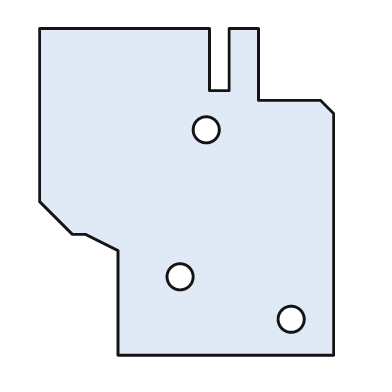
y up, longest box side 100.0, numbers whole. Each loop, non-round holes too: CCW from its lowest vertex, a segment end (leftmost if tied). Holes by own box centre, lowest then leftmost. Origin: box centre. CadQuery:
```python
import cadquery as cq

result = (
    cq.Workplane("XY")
    .moveTo(-21.0, -50.0)
    .lineTo(45.0, -50.0)
    .lineTo(45.0, 24.0)
    .lineTo(41.0, 28.0)
    .lineTo(22.0, 28.0)
    .lineTo(22.0, 50.0)
    .lineTo(13.0, 50.0)
    .lineTo(13.0, 31.0)
    .lineTo(7.0, 31.0)
    .lineTo(7.0, 50.0)
    .lineTo(-45.0, 50.0)
    .lineTo(-45.0, -3.0)
    .lineTo(-35.0, -13.0)
    .lineTo(-31.0, -13.0)
    .lineTo(-21.0, -18.0)
    .close()
    .moveTo(32.0, -39.0)
    .circle(4.0)
    .moveTo(-2.0, -26.0)
    .circle(4.0)
    .moveTo(6.0, 19.0)
    .circle(4.0)
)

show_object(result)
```